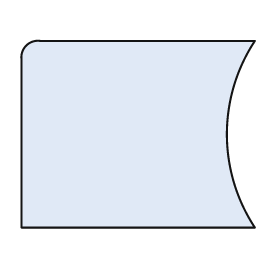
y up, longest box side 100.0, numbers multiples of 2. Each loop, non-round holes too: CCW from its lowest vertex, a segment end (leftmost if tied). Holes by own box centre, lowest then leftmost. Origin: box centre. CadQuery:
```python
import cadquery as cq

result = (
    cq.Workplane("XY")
    .moveTo(-50.0, -40.0)
    .lineTo(50.0, -40.0)
    .threePointArc((38.0, 0.0), (50.0, 40.0))
    .lineTo(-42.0, 40.0)
    .threePointArc((-48.0, 38.0), (-50.0, 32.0))
    .close()
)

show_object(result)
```